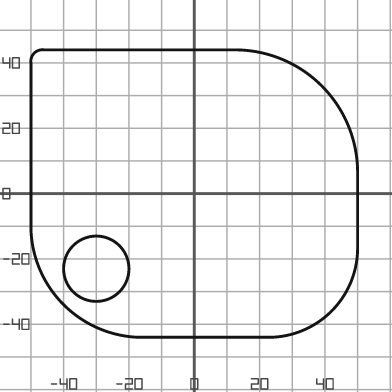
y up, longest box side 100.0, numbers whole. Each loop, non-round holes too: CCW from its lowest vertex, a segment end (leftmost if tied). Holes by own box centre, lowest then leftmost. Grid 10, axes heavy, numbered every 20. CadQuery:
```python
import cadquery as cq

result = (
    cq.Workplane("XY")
    .moveTo(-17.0, -44.0)
    .lineTo(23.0, -44.0)
    .threePointArc((42.0, -36.0), (50.0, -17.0))
    .lineTo(50.0, 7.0)
    .threePointArc((39.0, 33.0), (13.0, 44.0))
    .lineTo(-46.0, 44.0)
    .threePointArc((-49.0, 43.0), (-50.0, 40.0))
    .lineTo(-50.0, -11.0)
    .threePointArc((-40.0, -34.0), (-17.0, -44.0))
    .close()
    .moveTo(-30.0, -23.0)
    .circle(10.0)
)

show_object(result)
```